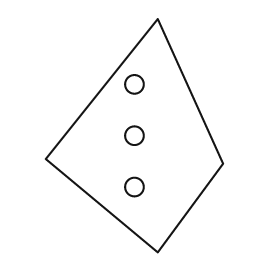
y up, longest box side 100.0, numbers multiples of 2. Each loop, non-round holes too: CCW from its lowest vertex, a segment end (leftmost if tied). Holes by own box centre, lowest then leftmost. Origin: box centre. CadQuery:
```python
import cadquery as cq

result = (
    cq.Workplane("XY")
    .moveTo(10.0, -50.0)
    .lineTo(38.0, -12.0)
    .lineTo(10.0, 50.0)
    .lineTo(-38.0, -10.0)
    .close()
    .moveTo(0.0, -22.0)
    .circle(4.0)
    .moveTo(0.0, 0.0)
    .circle(4.0)
    .moveTo(0.0, 22.0)
    .circle(4.0)
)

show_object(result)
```